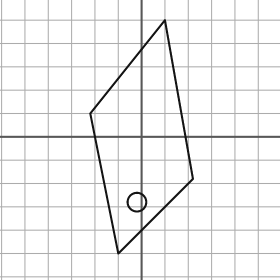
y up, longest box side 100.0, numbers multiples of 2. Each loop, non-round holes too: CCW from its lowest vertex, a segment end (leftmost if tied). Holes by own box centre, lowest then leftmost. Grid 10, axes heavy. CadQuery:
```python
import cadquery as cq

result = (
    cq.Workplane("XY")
    .moveTo(-10.0, -50.0)
    .lineTo(22.0, -18.0)
    .lineTo(10.0, 50.0)
    .lineTo(-22.0, 10.0)
    .close()
    .moveTo(-2.0, -28.0)
    .circle(4.0)
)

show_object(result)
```